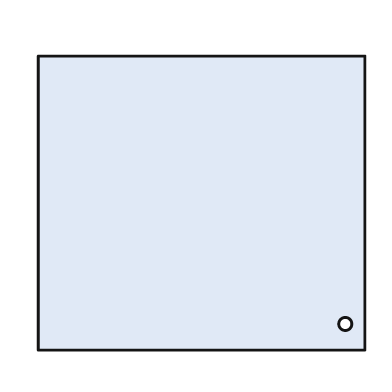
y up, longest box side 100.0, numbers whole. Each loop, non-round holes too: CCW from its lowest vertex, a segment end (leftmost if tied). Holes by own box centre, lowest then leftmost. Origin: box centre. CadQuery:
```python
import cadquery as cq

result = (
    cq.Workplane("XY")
    .moveTo(-50.0, -45.0)
    .lineTo(50.0, -45.0)
    .lineTo(50.0, 45.0)
    .lineTo(-50.0, 45.0)
    .close()
    .moveTo(44.0, -37.0)
    .circle(2.0)
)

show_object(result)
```